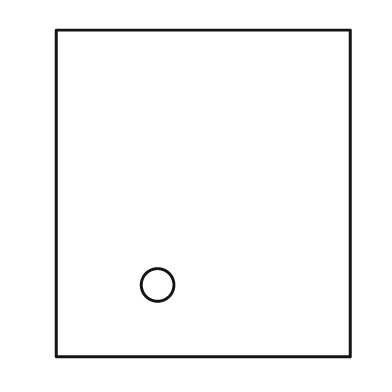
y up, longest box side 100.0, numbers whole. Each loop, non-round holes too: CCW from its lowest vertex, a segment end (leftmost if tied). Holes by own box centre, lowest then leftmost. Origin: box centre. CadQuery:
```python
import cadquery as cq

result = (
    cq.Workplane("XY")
    .moveTo(-45.0, -50.0)
    .lineTo(45.0, -50.0)
    .lineTo(45.0, 50.0)
    .lineTo(-45.0, 50.0)
    .close()
    .moveTo(-14.0, -28.0)
    .circle(5.0)
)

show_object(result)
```